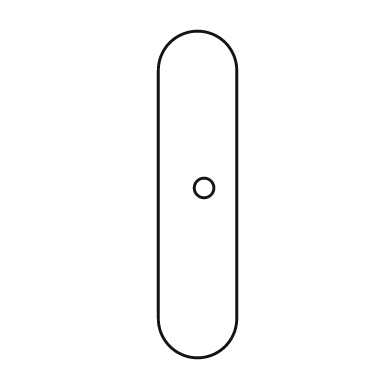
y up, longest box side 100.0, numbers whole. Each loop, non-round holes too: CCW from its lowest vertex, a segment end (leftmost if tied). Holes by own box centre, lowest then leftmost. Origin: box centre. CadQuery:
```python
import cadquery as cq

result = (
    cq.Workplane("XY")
    .moveTo(-12.0, -38.0)
    .threePointArc((0.0, -50.0), (12.0, -38.0))
    .lineTo(12.0, 38.0)
    .threePointArc((0.0, 50.0), (-12.0, 38.0))
    .close()
    .moveTo(2.0, 2.0)
    .circle(3.0)
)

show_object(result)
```